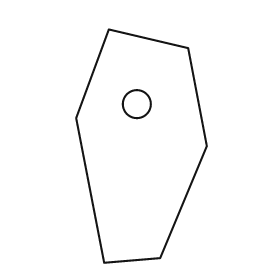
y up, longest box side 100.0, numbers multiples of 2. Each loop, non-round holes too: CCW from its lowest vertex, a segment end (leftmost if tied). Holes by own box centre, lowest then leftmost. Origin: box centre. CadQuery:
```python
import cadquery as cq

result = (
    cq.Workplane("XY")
    .moveTo(-16.0, -50.0)
    .lineTo(8.0, -48.0)
    .lineTo(28.0, 0.0)
    .lineTo(20.0, 42.0)
    .lineTo(-14.0, 50.0)
    .lineTo(-28.0, 12.0)
    .close()
    .moveTo(-2.0, 18.0)
    .circle(6.0)
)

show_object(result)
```